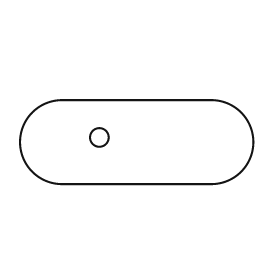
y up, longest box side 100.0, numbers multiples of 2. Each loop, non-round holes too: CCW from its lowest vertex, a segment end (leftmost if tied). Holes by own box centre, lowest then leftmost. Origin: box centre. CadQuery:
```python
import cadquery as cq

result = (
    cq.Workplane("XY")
    .moveTo(-32.0, -18.0)
    .lineTo(32.0, -18.0)
    .threePointArc((50.0, 0.0), (32.0, 18.0))
    .lineTo(-32.0, 18.0)
    .threePointArc((-50.0, 0.0), (-32.0, -18.0))
    .close()
    .moveTo(-16.0, 2.0)
    .circle(4.0)
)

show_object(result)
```